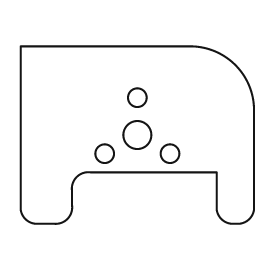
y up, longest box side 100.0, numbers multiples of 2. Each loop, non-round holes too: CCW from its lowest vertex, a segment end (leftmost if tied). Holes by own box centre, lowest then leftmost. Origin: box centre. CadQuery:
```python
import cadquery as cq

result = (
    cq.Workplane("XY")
    .moveTo(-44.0, -38.0)
    .lineTo(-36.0, -38.0)
    .threePointArc((-30.0, -36.0), (-28.0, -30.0))
    .lineTo(-28.0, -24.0)
    .threePointArc((-26.0, -18.0), (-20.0, -16.0))
    .lineTo(34.0, -16.0)
    .lineTo(34.0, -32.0)
    .threePointArc((36.0, -36.0), (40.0, -38.0))
    .lineTo(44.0, -38.0)
    .threePointArc((48.0, -36.0), (50.0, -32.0))
    .lineTo(50.0, 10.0)
    .threePointArc((42.0, 30.0), (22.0, 38.0))
    .lineTo(-50.0, 38.0)
    .lineTo(-50.0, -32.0)
    .threePointArc((-48.0, -36.0), (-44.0, -38.0))
    .close()
    .moveTo(-14.0, -8.0)
    .circle(4.0)
    .moveTo(14.0, -8.0)
    .circle(4.0)
    .moveTo(0.0, 0.0)
    .circle(6.0)
    .moveTo(0.0, 16.0)
    .circle(4.0)
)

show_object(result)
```